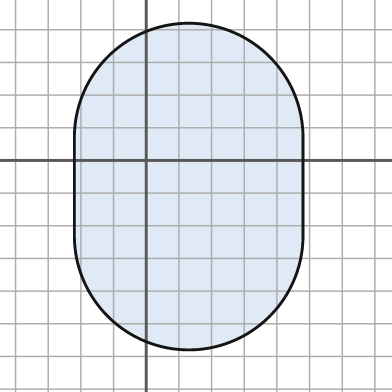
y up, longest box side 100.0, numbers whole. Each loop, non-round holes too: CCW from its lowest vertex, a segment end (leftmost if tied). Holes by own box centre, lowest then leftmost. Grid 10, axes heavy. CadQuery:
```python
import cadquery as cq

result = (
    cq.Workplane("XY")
    .moveTo(-22.0, -23.0)
    .threePointArc((13.0, -58.0), (48.0, -23.0))
    .lineTo(48.0, 7.0)
    .threePointArc((13.0, 42.0), (-22.0, 7.0))
    .close()
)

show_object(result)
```